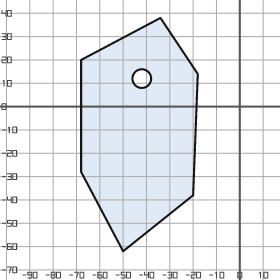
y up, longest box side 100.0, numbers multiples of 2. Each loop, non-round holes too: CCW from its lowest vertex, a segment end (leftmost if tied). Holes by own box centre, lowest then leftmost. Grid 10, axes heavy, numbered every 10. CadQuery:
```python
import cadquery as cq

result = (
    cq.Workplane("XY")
    .moveTo(-50.0, -62.0)
    .lineTo(-20.0, -38.0)
    .lineTo(-18.0, 14.0)
    .lineTo(-34.0, 38.0)
    .lineTo(-68.0, 20.0)
    .lineTo(-68.0, -28.0)
    .close()
    .moveTo(-42.0, 12.0)
    .circle(4.0)
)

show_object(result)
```